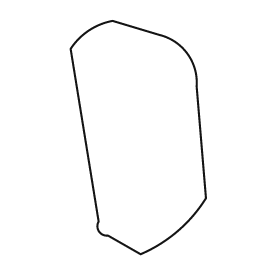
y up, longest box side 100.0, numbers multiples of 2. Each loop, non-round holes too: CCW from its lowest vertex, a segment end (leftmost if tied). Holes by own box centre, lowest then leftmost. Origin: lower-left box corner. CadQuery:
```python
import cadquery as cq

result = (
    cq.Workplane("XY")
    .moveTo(30.0, 0.0)
    .threePointArc((46.0, 10.0), (58.0, 24.0))
    .lineTo(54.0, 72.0)
    .threePointArc((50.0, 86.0), (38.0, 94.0))
    .lineTo(18.0, 100.0)
    .threePointArc((8.0, 96.0), (0.0, 88.0))
    .lineTo(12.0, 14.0)
    .threePointArc((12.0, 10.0), (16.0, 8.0))
    .close()
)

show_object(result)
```